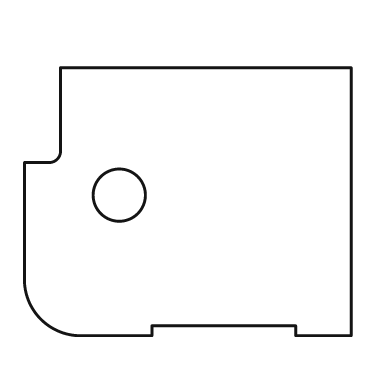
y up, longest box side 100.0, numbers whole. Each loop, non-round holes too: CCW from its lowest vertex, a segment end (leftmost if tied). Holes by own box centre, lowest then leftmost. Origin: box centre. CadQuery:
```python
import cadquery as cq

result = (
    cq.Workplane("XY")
    .moveTo(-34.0, -41.0)
    .lineTo(-11.0, -41.0)
    .lineTo(-11.0, -38.0)
    .lineTo(33.0, -38.0)
    .lineTo(33.0, -41.0)
    .lineTo(50.0, -41.0)
    .lineTo(50.0, 41.0)
    .lineTo(-39.0, 41.0)
    .lineTo(-39.0, 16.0)
    .threePointArc((-40.0, 13.0), (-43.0, 12.0))
    .lineTo(-50.0, 12.0)
    .lineTo(-50.0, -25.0)
    .threePointArc((-45.0, -36.0), (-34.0, -41.0))
    .close()
    .moveTo(-21.0, 2.0)
    .circle(8.0)
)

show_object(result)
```